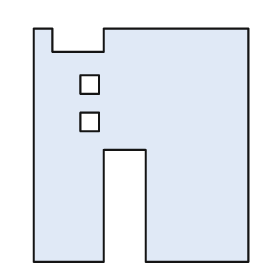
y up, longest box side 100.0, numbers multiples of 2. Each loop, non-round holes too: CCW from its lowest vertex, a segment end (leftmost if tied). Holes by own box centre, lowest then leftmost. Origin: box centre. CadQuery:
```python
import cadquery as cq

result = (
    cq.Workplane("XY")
    .moveTo(-46.0, -50.0)
    .lineTo(-16.0, -50.0)
    .lineTo(-16.0, -2.0)
    .lineTo(2.0, -2.0)
    .lineTo(2.0, -50.0)
    .lineTo(46.0, -50.0)
    .lineTo(46.0, 50.0)
    .lineTo(-16.0, 50.0)
    .lineTo(-16.0, 40.0)
    .lineTo(-38.0, 40.0)
    .lineTo(-38.0, 50.0)
    .lineTo(-46.0, 50.0)
    .close()
    .moveTo(-26.0, 6.0)
    .lineTo(-18.0, 6.0)
    .lineTo(-18.0, 14.0)
    .lineTo(-26.0, 14.0)
    .close()
    .moveTo(-26.0, 22.0)
    .lineTo(-18.0, 22.0)
    .lineTo(-18.0, 30.0)
    .lineTo(-26.0, 30.0)
    .close()
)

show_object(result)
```